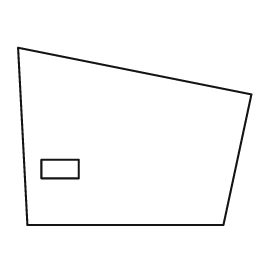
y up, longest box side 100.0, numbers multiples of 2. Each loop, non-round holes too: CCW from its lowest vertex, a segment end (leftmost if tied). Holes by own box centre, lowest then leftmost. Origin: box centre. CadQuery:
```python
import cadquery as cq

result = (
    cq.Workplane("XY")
    .moveTo(-46.0, -38.0)
    .lineTo(38.0, -38.0)
    .lineTo(50.0, 18.0)
    .lineTo(-50.0, 38.0)
    .close()
    .moveTo(-40.0, -18.0)
    .lineTo(-24.0, -18.0)
    .lineTo(-24.0, -10.0)
    .lineTo(-40.0, -10.0)
    .close()
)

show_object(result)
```